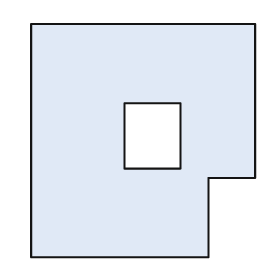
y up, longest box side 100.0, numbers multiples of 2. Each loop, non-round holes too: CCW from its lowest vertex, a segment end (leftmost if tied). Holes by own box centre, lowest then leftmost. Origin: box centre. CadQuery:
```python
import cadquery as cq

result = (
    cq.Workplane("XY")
    .moveTo(-48.0, -50.0)
    .lineTo(28.0, -50.0)
    .lineTo(28.0, -16.0)
    .lineTo(48.0, -16.0)
    .lineTo(48.0, 50.0)
    .lineTo(-48.0, 50.0)
    .close()
    .moveTo(-8.0, -12.0)
    .lineTo(16.0, -12.0)
    .lineTo(16.0, 16.0)
    .lineTo(-8.0, 16.0)
    .close()
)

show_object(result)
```